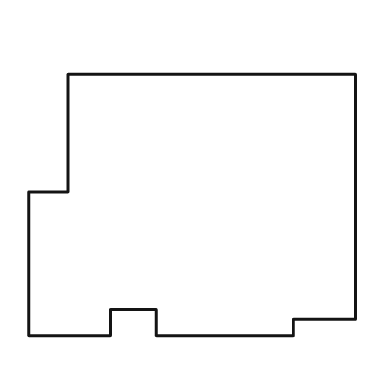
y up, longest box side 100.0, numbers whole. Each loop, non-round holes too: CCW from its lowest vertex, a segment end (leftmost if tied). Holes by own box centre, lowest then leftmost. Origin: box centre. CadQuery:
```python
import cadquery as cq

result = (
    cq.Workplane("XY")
    .moveTo(-50.0, -40.0)
    .lineTo(-25.0, -40.0)
    .lineTo(-25.0, -32.0)
    .lineTo(-11.0, -32.0)
    .lineTo(-11.0, -40.0)
    .lineTo(31.0, -40.0)
    .lineTo(31.0, -35.0)
    .lineTo(50.0, -35.0)
    .lineTo(50.0, 40.0)
    .lineTo(-38.0, 40.0)
    .lineTo(-38.0, 4.0)
    .lineTo(-50.0, 4.0)
    .close()
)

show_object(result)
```